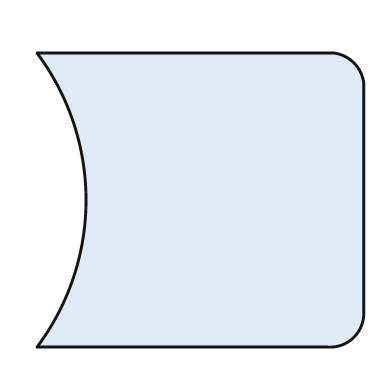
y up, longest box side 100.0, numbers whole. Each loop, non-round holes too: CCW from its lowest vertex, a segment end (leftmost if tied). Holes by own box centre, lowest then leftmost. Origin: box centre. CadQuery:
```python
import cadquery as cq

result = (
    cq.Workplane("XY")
    .moveTo(-50.0, -45.0)
    .lineTo(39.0, -45.0)
    .threePointArc((47.0, -42.0), (50.0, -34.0))
    .lineTo(50.0, 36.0)
    .threePointArc((47.0, 42.0), (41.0, 45.0))
    .lineTo(-50.0, 45.0)
    .threePointArc((-35.0, 0.0), (-50.0, -45.0))
    .close()
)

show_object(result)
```